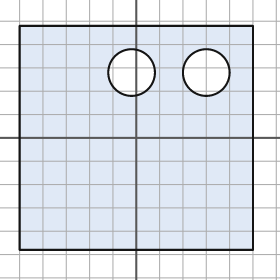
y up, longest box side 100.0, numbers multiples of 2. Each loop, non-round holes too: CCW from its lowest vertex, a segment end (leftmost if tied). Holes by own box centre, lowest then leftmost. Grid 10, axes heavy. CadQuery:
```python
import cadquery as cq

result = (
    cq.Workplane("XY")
    .moveTo(-50.0, -48.0)
    .lineTo(50.0, -48.0)
    .lineTo(50.0, 48.0)
    .lineTo(-50.0, 48.0)
    .close()
    .moveTo(-2.0, 28.0)
    .circle(10.0)
    .moveTo(30.0, 28.0)
    .circle(10.0)
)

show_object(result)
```